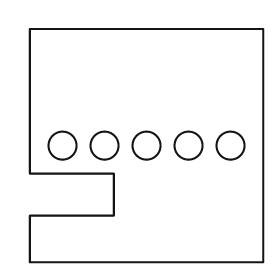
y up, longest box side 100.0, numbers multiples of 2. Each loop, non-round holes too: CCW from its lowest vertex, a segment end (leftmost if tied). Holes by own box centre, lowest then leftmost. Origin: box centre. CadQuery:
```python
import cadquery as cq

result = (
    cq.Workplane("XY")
    .moveTo(-50.0, -50.0)
    .lineTo(50.0, -50.0)
    .lineTo(50.0, 50.0)
    .lineTo(-50.0, 50.0)
    .lineTo(-50.0, -12.0)
    .lineTo(-14.0, -12.0)
    .lineTo(-14.0, -30.0)
    .lineTo(-50.0, -30.0)
    .close()
    .moveTo(-36.0, 0.0)
    .circle(6.0)
    .moveTo(-18.0, 0.0)
    .circle(6.0)
    .moveTo(0.0, 0.0)
    .circle(6.0)
    .moveTo(18.0, 0.0)
    .circle(6.0)
    .moveTo(36.0, 0.0)
    .circle(6.0)
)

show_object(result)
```